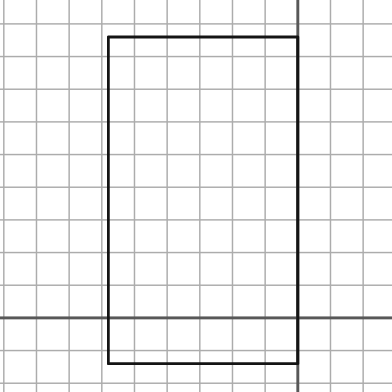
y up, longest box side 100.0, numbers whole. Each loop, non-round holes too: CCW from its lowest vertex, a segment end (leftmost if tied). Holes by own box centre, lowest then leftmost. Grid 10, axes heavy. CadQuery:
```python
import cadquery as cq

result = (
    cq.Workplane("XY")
    .moveTo(-58.0, -14.0)
    .lineTo(0.0, -14.0)
    .lineTo(0.0, 86.0)
    .lineTo(-58.0, 86.0)
    .close()
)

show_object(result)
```